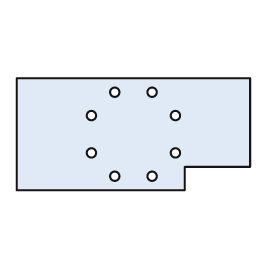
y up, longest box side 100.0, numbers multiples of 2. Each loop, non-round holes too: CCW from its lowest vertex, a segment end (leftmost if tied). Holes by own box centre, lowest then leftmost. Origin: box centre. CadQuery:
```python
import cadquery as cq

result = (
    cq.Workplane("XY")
    .moveTo(-50.0, -24.0)
    .lineTo(22.0, -24.0)
    .lineTo(22.0, -14.0)
    .lineTo(50.0, -14.0)
    .lineTo(50.0, 24.0)
    .lineTo(-50.0, 24.0)
    .close()
    .moveTo(-8.0, -18.0)
    .circle(2.0)
    .moveTo(8.0, -18.0)
    .circle(2.0)
    .moveTo(-18.0, -8.0)
    .circle(2.0)
    .moveTo(18.0, -8.0)
    .circle(2.0)
    .moveTo(-18.0, 8.0)
    .circle(2.0)
    .moveTo(18.0, 8.0)
    .circle(2.0)
    .moveTo(-8.0, 18.0)
    .circle(2.0)
    .moveTo(8.0, 18.0)
    .circle(2.0)
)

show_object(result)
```